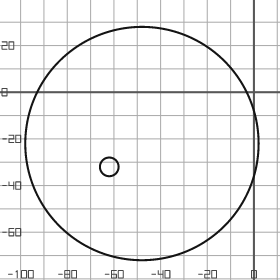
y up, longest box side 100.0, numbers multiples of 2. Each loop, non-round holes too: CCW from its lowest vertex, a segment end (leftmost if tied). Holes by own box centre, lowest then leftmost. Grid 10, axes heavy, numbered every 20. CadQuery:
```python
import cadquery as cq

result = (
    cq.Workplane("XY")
    .moveTo(-48.0, -22.0)
    .circle(50.0)
    .moveTo(-62.0, -32.0)
    .circle(4.0)
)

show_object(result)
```